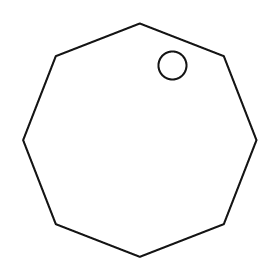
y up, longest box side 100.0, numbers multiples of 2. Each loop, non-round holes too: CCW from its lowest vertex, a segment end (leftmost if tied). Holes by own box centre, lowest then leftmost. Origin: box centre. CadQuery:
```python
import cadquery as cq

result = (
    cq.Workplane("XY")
    .moveTo(0.0, -50.0)
    .lineTo(36.0, -36.0)
    .lineTo(50.0, 0.0)
    .lineTo(36.0, 36.0)
    .lineTo(0.0, 50.0)
    .lineTo(-36.0, 36.0)
    .lineTo(-50.0, 0.0)
    .lineTo(-36.0, -36.0)
    .close()
    .moveTo(14.0, 32.0)
    .circle(6.0)
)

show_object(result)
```